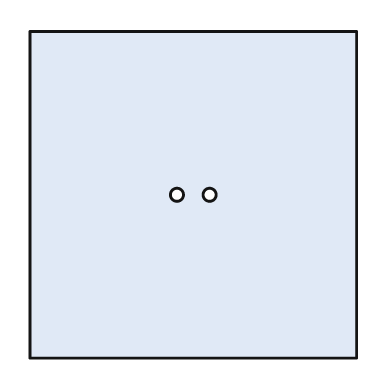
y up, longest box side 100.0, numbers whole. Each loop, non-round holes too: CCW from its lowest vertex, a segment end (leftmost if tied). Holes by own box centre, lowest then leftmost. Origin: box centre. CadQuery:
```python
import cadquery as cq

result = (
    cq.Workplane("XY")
    .moveTo(-50.0, -50.0)
    .lineTo(50.0, -50.0)
    .lineTo(50.0, 50.0)
    .lineTo(-50.0, 50.0)
    .close()
    .moveTo(-5.0, 0.0)
    .circle(2.0)
    .moveTo(5.0, 0.0)
    .circle(2.0)
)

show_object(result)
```